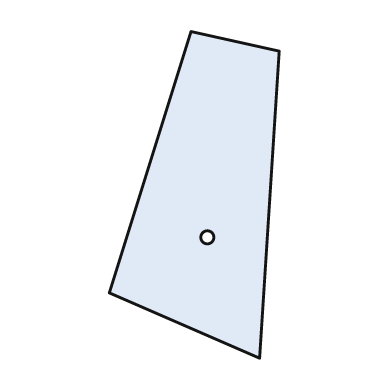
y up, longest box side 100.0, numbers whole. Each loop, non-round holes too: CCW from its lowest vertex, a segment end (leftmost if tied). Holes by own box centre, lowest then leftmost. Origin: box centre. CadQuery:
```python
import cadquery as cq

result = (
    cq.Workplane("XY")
    .moveTo(20.0, -50.0)
    .lineTo(26.0, 44.0)
    .lineTo(-1.0, 50.0)
    .lineTo(-26.0, -30.0)
    .close()
    .moveTo(4.0, -13.0)
    .circle(2.0)
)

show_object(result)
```